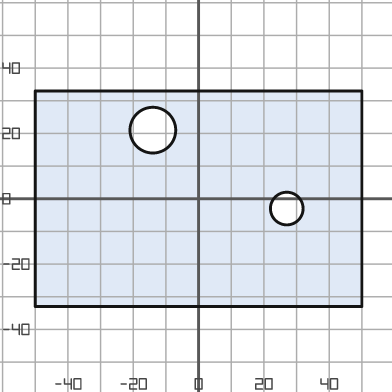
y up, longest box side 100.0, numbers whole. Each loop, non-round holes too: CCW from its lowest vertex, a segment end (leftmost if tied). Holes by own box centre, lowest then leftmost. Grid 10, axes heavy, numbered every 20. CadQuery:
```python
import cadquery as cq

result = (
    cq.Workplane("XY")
    .moveTo(-50.0, -33.0)
    .lineTo(50.0, -33.0)
    .lineTo(50.0, 33.0)
    .lineTo(-50.0, 33.0)
    .close()
    .moveTo(27.0, -3.0)
    .circle(5.0)
    .moveTo(-14.0, 21.0)
    .circle(7.0)
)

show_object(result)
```